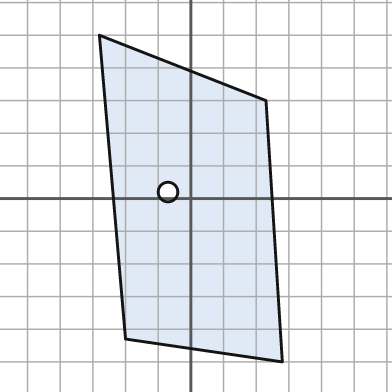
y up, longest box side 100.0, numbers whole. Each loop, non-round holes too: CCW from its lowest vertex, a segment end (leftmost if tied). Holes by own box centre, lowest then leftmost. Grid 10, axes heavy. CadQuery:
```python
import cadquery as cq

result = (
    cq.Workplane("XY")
    .moveTo(28.0, -50.0)
    .lineTo(23.0, 30.0)
    .lineTo(-28.0, 50.0)
    .lineTo(-20.0, -43.0)
    .close()
    .moveTo(-7.0, 2.0)
    .circle(3.0)
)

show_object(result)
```